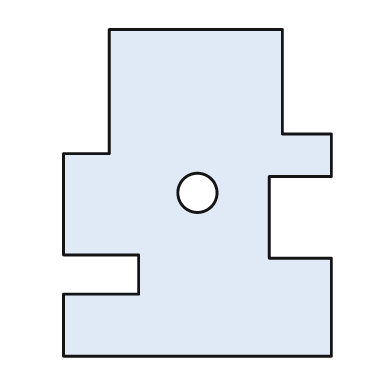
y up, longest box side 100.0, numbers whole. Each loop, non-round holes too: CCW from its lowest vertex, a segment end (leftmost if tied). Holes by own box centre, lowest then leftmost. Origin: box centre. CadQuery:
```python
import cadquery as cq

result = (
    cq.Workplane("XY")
    .moveTo(-41.0, -50.0)
    .lineTo(41.0, -50.0)
    .lineTo(41.0, -20.0)
    .lineTo(22.0, -20.0)
    .lineTo(22.0, 5.0)
    .lineTo(41.0, 5.0)
    .lineTo(41.0, 18.0)
    .lineTo(26.0, 18.0)
    .lineTo(26.0, 50.0)
    .lineTo(-27.0, 50.0)
    .lineTo(-27.0, 12.0)
    .lineTo(-41.0, 12.0)
    .lineTo(-41.0, -19.0)
    .lineTo(-18.0, -19.0)
    .lineTo(-18.0, -31.0)
    .lineTo(-41.0, -31.0)
    .close()
    .moveTo(0.0, 0.0)
    .circle(6.0)
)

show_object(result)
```